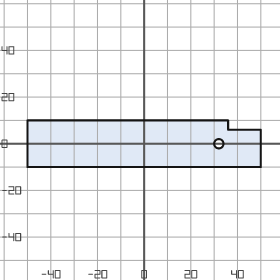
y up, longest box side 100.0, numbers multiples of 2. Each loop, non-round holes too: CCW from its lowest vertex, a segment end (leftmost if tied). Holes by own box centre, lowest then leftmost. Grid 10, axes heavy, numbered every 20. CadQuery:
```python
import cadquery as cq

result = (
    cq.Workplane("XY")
    .moveTo(-50.0, -10.0)
    .lineTo(50.0, -10.0)
    .lineTo(50.0, 6.0)
    .lineTo(36.0, 6.0)
    .lineTo(36.0, 10.0)
    .lineTo(-50.0, 10.0)
    .close()
    .moveTo(32.0, 0.0)
    .circle(2.0)
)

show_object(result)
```